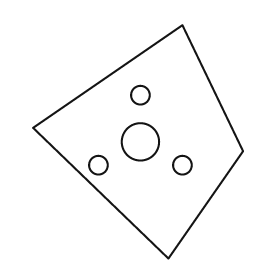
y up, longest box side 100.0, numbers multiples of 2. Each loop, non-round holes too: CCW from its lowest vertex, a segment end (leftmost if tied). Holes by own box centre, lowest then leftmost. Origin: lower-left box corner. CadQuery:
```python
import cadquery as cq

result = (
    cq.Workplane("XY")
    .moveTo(58.0, 0.0)
    .lineTo(90.0, 46.0)
    .lineTo(64.0, 100.0)
    .lineTo(0.0, 56.0)
    .close()
    .moveTo(28.0, 40.0)
    .circle(4.0)
    .moveTo(64.0, 40.0)
    .circle(4.0)
    .moveTo(46.0, 50.0)
    .circle(8.0)
    .moveTo(46.0, 70.0)
    .circle(4.0)
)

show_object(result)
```